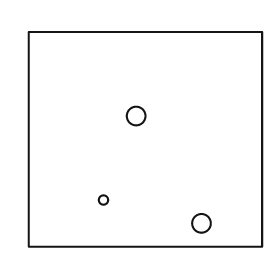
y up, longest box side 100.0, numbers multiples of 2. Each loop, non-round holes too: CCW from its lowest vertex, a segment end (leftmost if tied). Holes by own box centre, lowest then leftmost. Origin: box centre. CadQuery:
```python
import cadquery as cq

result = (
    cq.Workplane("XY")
    .moveTo(-50.0, -46.0)
    .lineTo(50.0, -46.0)
    .lineTo(50.0, 46.0)
    .lineTo(-50.0, 46.0)
    .close()
    .moveTo(24.0, -36.0)
    .circle(4.0)
    .moveTo(-18.0, -26.0)
    .circle(2.0)
    .moveTo(-4.0, 10.0)
    .circle(4.0)
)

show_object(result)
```